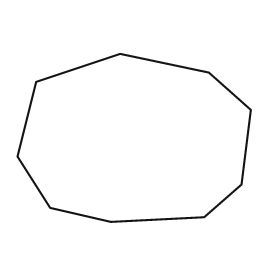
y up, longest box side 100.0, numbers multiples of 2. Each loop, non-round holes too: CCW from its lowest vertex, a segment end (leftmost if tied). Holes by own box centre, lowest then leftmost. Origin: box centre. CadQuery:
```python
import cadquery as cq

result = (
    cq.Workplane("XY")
    .moveTo(-10.0, -36.0)
    .lineTo(30.0, -34.0)
    .lineTo(46.0, -20.0)
    .lineTo(50.0, 12.0)
    .lineTo(32.0, 28.0)
    .lineTo(-6.0, 36.0)
    .lineTo(-42.0, 24.0)
    .lineTo(-50.0, -8.0)
    .lineTo(-36.0, -30.0)
    .close()
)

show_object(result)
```